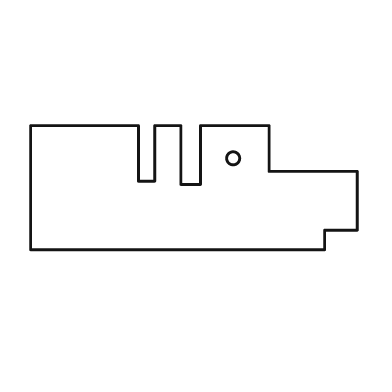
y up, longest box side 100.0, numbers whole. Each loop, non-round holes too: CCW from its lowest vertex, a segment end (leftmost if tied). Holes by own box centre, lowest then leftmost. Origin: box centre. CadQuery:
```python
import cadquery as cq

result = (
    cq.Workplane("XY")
    .moveTo(-50.0, -19.0)
    .lineTo(40.0, -19.0)
    .lineTo(40.0, -13.0)
    .lineTo(50.0, -13.0)
    .lineTo(50.0, 5.0)
    .lineTo(23.0, 5.0)
    .lineTo(23.0, 19.0)
    .lineTo(2.0, 19.0)
    .lineTo(2.0, 1.0)
    .lineTo(-4.0, 1.0)
    .lineTo(-4.0, 19.0)
    .lineTo(-12.0, 19.0)
    .lineTo(-12.0, 2.0)
    .lineTo(-17.0, 2.0)
    .lineTo(-17.0, 19.0)
    .lineTo(-50.0, 19.0)
    .close()
    .moveTo(12.0, 9.0)
    .circle(2.0)
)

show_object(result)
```